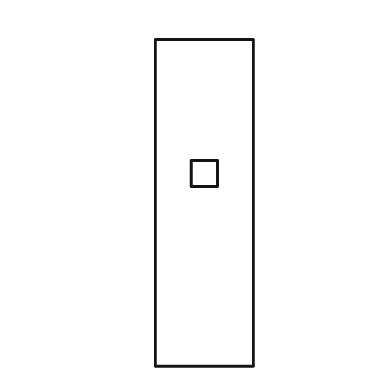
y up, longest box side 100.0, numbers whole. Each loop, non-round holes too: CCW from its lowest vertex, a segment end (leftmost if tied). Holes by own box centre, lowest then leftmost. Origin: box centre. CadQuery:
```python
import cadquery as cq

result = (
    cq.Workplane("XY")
    .moveTo(-15.0, -50.0)
    .lineTo(15.0, -50.0)
    .lineTo(15.0, 50.0)
    .lineTo(-15.0, 50.0)
    .close()
    .moveTo(-4.0, 5.0)
    .lineTo(4.0, 5.0)
    .lineTo(4.0, 13.0)
    .lineTo(-4.0, 13.0)
    .close()
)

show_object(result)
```